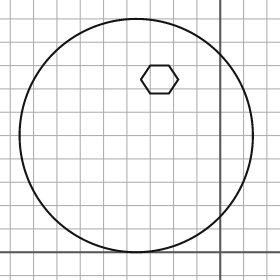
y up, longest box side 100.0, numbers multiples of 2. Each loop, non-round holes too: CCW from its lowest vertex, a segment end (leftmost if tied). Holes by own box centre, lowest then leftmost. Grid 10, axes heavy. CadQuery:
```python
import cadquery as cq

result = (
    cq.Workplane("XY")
    .moveTo(-36.0, 50.0)
    .circle(50.0)
    .moveTo(-30.0, 68.0)
    .lineTo(-22.0, 68.0)
    .lineTo(-18.0, 74.0)
    .lineTo(-22.0, 80.0)
    .lineTo(-30.0, 80.0)
    .lineTo(-34.0, 74.0)
    .close()
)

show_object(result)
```